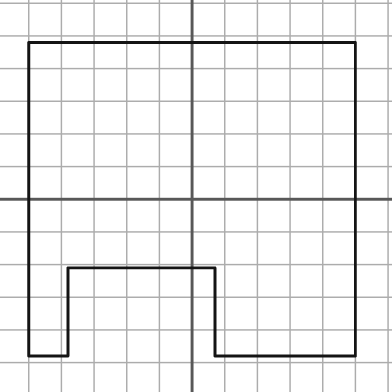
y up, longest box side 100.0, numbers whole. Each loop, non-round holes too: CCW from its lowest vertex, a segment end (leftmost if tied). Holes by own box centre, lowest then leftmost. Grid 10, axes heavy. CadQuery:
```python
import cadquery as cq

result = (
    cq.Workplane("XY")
    .moveTo(-50.0, -48.0)
    .lineTo(-38.0, -48.0)
    .lineTo(-38.0, -21.0)
    .lineTo(7.0, -21.0)
    .lineTo(7.0, -48.0)
    .lineTo(50.0, -48.0)
    .lineTo(50.0, 48.0)
    .lineTo(-50.0, 48.0)
    .close()
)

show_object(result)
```